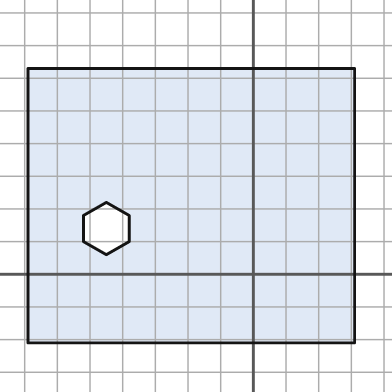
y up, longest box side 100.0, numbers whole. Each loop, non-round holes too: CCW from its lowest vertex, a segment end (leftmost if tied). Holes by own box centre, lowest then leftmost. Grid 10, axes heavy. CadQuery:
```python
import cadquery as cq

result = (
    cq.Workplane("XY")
    .moveTo(-69.0, -21.0)
    .lineTo(31.0, -21.0)
    .lineTo(31.0, 63.0)
    .lineTo(-69.0, 63.0)
    .close()
    .moveTo(-45.0, 6.0)
    .lineTo(-38.0, 10.0)
    .lineTo(-38.0, 18.0)
    .lineTo(-45.0, 22.0)
    .lineTo(-52.0, 18.0)
    .lineTo(-52.0, 10.0)
    .close()
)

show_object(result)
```